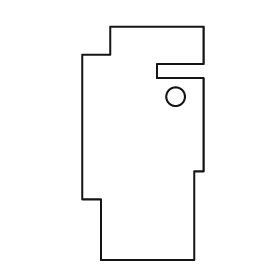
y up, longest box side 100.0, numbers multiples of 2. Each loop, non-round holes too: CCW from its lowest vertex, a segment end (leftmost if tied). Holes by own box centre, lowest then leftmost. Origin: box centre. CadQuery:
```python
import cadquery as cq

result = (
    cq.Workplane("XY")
    .moveTo(-18.0, -50.0)
    .lineTo(22.0, -50.0)
    .lineTo(22.0, -12.0)
    .lineTo(26.0, -12.0)
    .lineTo(26.0, 28.0)
    .lineTo(6.0, 28.0)
    .lineTo(6.0, 34.0)
    .lineTo(26.0, 34.0)
    .lineTo(26.0, 50.0)
    .lineTo(-14.0, 50.0)
    .lineTo(-14.0, 38.0)
    .lineTo(-26.0, 38.0)
    .lineTo(-26.0, -24.0)
    .lineTo(-18.0, -24.0)
    .close()
    .moveTo(14.0, 20.0)
    .circle(4.0)
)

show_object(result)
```